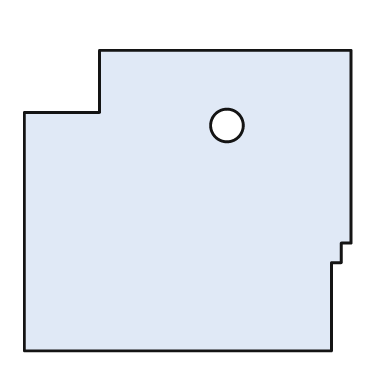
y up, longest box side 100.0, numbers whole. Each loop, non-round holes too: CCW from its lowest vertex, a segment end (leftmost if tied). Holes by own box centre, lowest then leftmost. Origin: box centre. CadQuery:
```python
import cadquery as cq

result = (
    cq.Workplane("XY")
    .moveTo(-50.0, -46.0)
    .lineTo(44.0, -46.0)
    .lineTo(44.0, -19.0)
    .lineTo(47.0, -19.0)
    .lineTo(47.0, -13.0)
    .lineTo(50.0, -13.0)
    .lineTo(50.0, 46.0)
    .lineTo(-27.0, 46.0)
    .lineTo(-27.0, 27.0)
    .lineTo(-50.0, 27.0)
    .close()
    .moveTo(12.0, 23.0)
    .circle(5.0)
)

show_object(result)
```